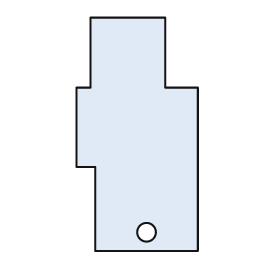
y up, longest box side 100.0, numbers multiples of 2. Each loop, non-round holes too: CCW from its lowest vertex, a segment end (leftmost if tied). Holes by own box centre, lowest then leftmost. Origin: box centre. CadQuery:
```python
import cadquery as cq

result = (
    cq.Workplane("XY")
    .moveTo(-18.0, -50.0)
    .lineTo(26.0, -50.0)
    .lineTo(26.0, 20.0)
    .lineTo(12.0, 20.0)
    .lineTo(12.0, 50.0)
    .lineTo(-20.0, 50.0)
    .lineTo(-20.0, 20.0)
    .lineTo(-26.0, 20.0)
    .lineTo(-26.0, -14.0)
    .lineTo(-18.0, -14.0)
    .close()
    .moveTo(4.0, -42.0)
    .circle(4.0)
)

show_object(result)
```